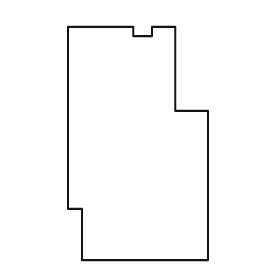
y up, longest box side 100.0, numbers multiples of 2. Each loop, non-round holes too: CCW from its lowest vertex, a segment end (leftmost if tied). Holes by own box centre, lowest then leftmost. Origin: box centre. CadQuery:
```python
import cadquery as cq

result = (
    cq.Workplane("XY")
    .moveTo(-24.0, -50.0)
    .lineTo(30.0, -50.0)
    .lineTo(30.0, 14.0)
    .lineTo(16.0, 14.0)
    .lineTo(16.0, 50.0)
    .lineTo(6.0, 50.0)
    .lineTo(6.0, 46.0)
    .lineTo(-2.0, 46.0)
    .lineTo(-2.0, 50.0)
    .lineTo(-30.0, 50.0)
    .lineTo(-30.0, -28.0)
    .lineTo(-24.0, -28.0)
    .close()
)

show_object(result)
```